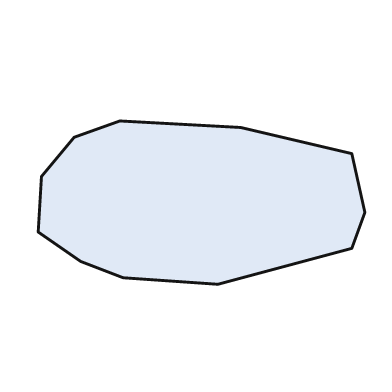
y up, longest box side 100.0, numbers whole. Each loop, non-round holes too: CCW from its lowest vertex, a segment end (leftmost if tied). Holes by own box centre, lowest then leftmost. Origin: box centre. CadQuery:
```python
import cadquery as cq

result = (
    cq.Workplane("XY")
    .moveTo(5.0, -25.0)
    .lineTo(46.0, -14.0)
    .lineTo(50.0, -3.0)
    .lineTo(46.0, 15.0)
    .lineTo(12.0, 23.0)
    .lineTo(-25.0, 25.0)
    .lineTo(-39.0, 20.0)
    .lineTo(-49.0, 8.0)
    .lineTo(-50.0, -9.0)
    .lineTo(-37.0, -18.0)
    .lineTo(-24.0, -23.0)
    .close()
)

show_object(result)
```